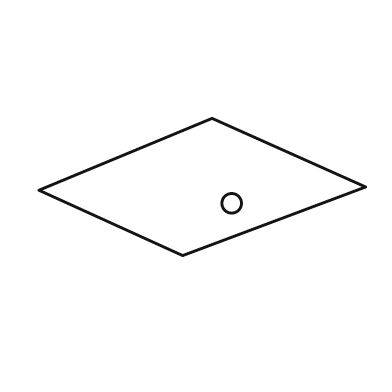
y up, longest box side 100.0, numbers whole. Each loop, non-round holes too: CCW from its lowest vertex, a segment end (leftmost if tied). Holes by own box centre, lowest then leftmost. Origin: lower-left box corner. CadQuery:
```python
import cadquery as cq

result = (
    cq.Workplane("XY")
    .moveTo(44.0, 0.0)
    .lineTo(100.0, 21.0)
    .lineTo(53.0, 42.0)
    .lineTo(0.0, 20.0)
    .close()
    .moveTo(59.0, 16.0)
    .circle(3.0)
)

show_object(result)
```